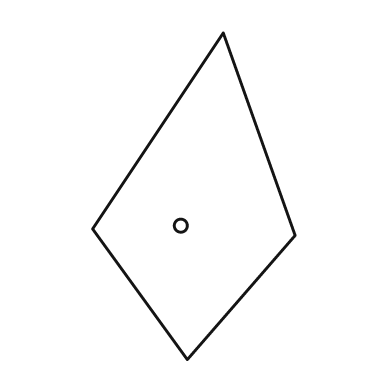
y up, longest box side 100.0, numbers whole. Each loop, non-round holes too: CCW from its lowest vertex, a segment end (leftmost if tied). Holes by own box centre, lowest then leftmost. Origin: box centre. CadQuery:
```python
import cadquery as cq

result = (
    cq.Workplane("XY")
    .moveTo(-2.0, -50.0)
    .lineTo(31.0, -12.0)
    .lineTo(9.0, 50.0)
    .lineTo(-31.0, -10.0)
    .close()
    .moveTo(-4.0, -9.0)
    .circle(2.0)
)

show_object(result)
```